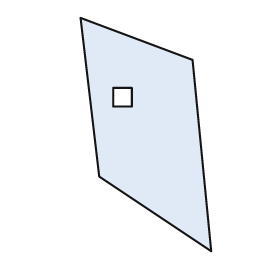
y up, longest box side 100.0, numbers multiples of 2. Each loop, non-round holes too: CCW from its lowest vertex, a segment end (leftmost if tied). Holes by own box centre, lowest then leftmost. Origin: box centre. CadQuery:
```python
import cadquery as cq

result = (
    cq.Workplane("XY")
    .moveTo(28.0, -50.0)
    .lineTo(20.0, 32.0)
    .lineTo(-28.0, 50.0)
    .lineTo(-20.0, -18.0)
    .close()
    .moveTo(-14.0, 12.0)
    .lineTo(-6.0, 12.0)
    .lineTo(-6.0, 20.0)
    .lineTo(-14.0, 20.0)
    .close()
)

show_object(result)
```